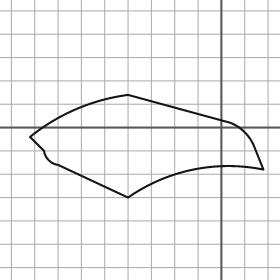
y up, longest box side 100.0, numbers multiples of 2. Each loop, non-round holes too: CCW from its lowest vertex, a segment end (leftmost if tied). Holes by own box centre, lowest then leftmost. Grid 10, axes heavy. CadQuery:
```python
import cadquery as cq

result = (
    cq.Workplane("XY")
    .moveTo(-40.0, -30.0)
    .threePointArc((-12.0, -18.0), (18.0, -18.0))
    .lineTo(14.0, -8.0)
    .threePointArc((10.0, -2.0), (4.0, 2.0))
    .lineTo(-40.0, 14.0)
    .threePointArc((-62.0, 8.0), (-82.0, -4.0))
    .lineTo(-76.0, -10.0)
    .threePointArc((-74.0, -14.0), (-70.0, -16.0))
    .close()
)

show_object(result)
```